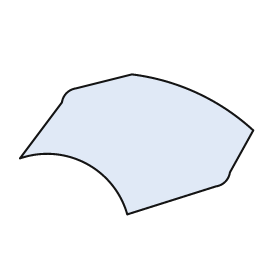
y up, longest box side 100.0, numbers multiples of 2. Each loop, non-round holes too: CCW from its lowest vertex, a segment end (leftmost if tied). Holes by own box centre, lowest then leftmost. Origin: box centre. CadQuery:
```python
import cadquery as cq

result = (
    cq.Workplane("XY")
    .moveTo(-4.0, -30.0)
    .lineTo(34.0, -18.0)
    .threePointArc((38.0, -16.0), (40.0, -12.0))
    .lineTo(50.0, 6.0)
    .threePointArc((26.0, 22.0), (-2.0, 30.0))
    .lineTo(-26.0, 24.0)
    .threePointArc((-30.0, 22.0), (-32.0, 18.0))
    .lineTo(-50.0, -6.0)
    .threePointArc((-22.0, -8.0), (-4.0, -30.0))
    .close()
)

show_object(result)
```